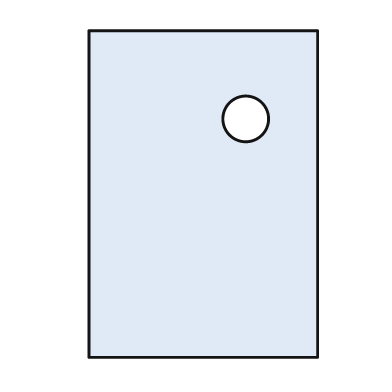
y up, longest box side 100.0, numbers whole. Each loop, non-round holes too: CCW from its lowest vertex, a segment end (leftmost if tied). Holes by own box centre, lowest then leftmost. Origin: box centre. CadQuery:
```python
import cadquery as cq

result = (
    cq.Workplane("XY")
    .moveTo(-35.0, -50.0)
    .lineTo(35.0, -50.0)
    .lineTo(35.0, 50.0)
    .lineTo(-35.0, 50.0)
    .close()
    .moveTo(13.0, 23.0)
    .circle(7.0)
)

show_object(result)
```